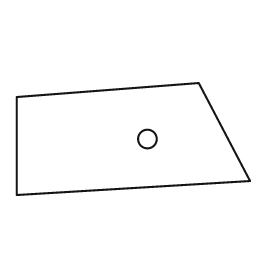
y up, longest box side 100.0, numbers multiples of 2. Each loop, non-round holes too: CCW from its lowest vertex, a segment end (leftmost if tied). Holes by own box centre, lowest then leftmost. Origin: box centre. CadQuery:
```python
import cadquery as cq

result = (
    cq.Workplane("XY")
    .moveTo(-50.0, -24.0)
    .lineTo(50.0, -18.0)
    .lineTo(28.0, 24.0)
    .lineTo(-50.0, 18.0)
    .close()
    .moveTo(6.0, 0.0)
    .circle(4.0)
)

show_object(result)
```